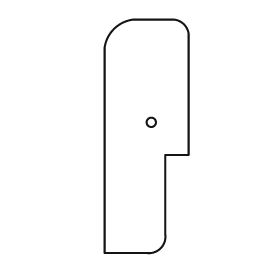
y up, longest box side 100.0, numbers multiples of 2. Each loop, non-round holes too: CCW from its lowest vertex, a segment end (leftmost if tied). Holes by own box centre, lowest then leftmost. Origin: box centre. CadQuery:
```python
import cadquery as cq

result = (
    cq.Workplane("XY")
    .moveTo(-18.0, -50.0)
    .lineTo(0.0, -50.0)
    .threePointArc((6.0, -48.0), (8.0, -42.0))
    .lineTo(8.0, -8.0)
    .lineTo(18.0, -8.0)
    .lineTo(18.0, 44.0)
    .threePointArc((16.0, 48.0), (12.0, 50.0))
    .lineTo(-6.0, 50.0)
    .threePointArc((-14.0, 46.0), (-18.0, 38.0))
    .close()
    .moveTo(2.0, 6.0)
    .circle(2.0)
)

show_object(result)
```